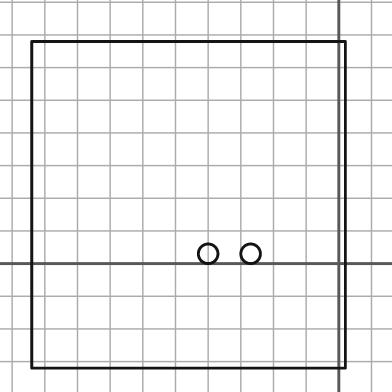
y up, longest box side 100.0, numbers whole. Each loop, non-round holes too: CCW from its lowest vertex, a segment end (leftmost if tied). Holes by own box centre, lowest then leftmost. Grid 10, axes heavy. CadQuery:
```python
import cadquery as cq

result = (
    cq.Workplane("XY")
    .moveTo(-94.0, -32.0)
    .lineTo(2.0, -32.0)
    .lineTo(2.0, 68.0)
    .lineTo(-94.0, 68.0)
    .close()
    .moveTo(-40.0, 3.0)
    .circle(3.0)
    .moveTo(-27.0, 3.0)
    .circle(3.0)
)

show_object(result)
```